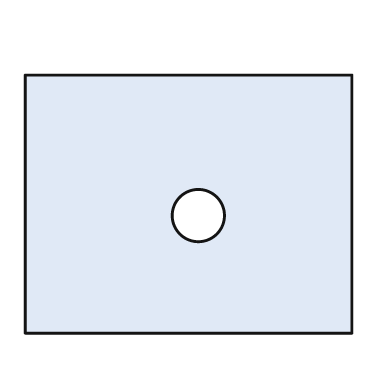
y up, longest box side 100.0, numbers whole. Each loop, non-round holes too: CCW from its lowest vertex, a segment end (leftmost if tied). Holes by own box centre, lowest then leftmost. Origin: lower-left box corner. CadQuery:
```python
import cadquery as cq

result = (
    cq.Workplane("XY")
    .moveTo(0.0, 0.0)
    .lineTo(100.0, 0.0)
    .lineTo(100.0, 79.0)
    .lineTo(0.0, 79.0)
    .close()
    .moveTo(53.0, 36.0)
    .circle(8.0)
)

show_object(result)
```